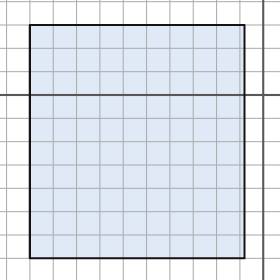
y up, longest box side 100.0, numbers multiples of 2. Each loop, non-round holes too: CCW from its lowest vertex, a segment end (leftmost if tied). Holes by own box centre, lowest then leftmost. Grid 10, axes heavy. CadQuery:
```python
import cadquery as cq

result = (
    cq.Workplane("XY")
    .moveTo(-100.0, -70.0)
    .lineTo(-8.0, -70.0)
    .lineTo(-8.0, 30.0)
    .lineTo(-100.0, 30.0)
    .close()
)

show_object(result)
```